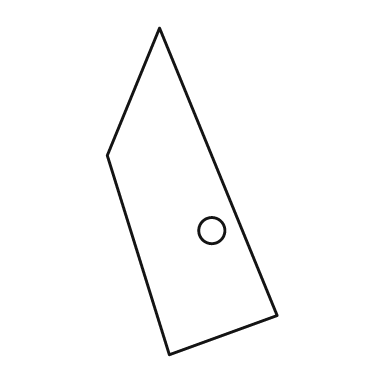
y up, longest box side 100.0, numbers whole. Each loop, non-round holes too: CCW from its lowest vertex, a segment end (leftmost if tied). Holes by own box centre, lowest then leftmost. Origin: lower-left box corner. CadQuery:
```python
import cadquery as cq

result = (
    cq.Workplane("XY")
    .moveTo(19.0, 0.0)
    .lineTo(52.0, 12.0)
    .lineTo(16.0, 100.0)
    .lineTo(0.0, 61.0)
    .close()
    .moveTo(32.0, 38.0)
    .circle(4.0)
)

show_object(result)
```